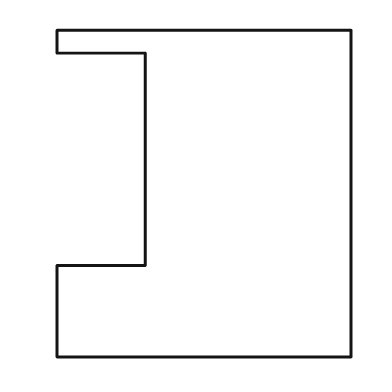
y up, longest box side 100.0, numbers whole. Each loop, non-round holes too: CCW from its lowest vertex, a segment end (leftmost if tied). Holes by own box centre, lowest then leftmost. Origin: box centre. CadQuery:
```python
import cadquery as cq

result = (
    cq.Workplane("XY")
    .moveTo(-45.0, -50.0)
    .lineTo(45.0, -50.0)
    .lineTo(45.0, 50.0)
    .lineTo(-45.0, 50.0)
    .lineTo(-45.0, 43.0)
    .lineTo(-18.0, 43.0)
    .lineTo(-18.0, -22.0)
    .lineTo(-45.0, -22.0)
    .close()
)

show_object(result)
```